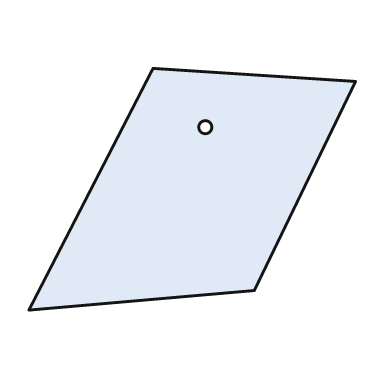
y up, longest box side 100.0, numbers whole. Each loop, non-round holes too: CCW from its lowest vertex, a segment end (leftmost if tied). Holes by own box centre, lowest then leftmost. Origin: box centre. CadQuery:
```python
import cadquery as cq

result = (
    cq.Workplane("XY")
    .moveTo(-50.0, -37.0)
    .lineTo(19.0, -31.0)
    .lineTo(50.0, 33.0)
    .lineTo(-12.0, 37.0)
    .close()
    .moveTo(4.0, 19.0)
    .circle(2.0)
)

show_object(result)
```